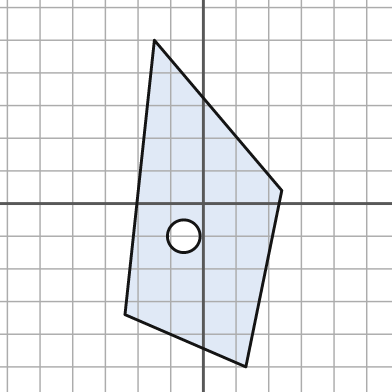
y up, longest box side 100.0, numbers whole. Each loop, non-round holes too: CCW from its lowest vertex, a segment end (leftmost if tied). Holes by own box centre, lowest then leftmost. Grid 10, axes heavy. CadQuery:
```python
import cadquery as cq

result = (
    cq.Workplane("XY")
    .moveTo(13.0, -50.0)
    .lineTo(24.0, 4.0)
    .lineTo(-15.0, 50.0)
    .lineTo(-24.0, -34.0)
    .close()
    .moveTo(-6.0, -10.0)
    .circle(5.0)
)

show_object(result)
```